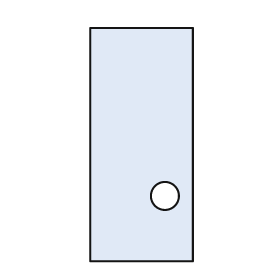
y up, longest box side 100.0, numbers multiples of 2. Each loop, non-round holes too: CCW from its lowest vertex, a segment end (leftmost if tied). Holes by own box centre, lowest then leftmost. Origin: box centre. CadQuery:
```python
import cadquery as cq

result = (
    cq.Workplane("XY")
    .moveTo(-22.0, -50.0)
    .lineTo(22.0, -50.0)
    .lineTo(22.0, 50.0)
    .lineTo(-22.0, 50.0)
    .close()
    .moveTo(10.0, -22.0)
    .circle(6.0)
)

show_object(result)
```